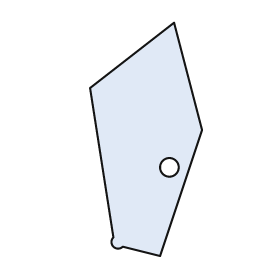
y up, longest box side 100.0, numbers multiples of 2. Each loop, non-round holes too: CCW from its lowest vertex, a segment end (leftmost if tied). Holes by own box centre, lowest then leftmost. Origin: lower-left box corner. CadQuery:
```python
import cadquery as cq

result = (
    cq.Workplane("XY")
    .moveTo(30.0, 0.0)
    .lineTo(48.0, 54.0)
    .lineTo(36.0, 100.0)
    .lineTo(0.0, 72.0)
    .lineTo(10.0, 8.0)
    .threePointArc((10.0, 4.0), (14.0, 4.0))
    .close()
    .moveTo(34.0, 38.0)
    .circle(4.0)
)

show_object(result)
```